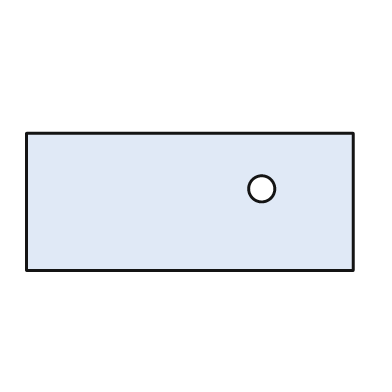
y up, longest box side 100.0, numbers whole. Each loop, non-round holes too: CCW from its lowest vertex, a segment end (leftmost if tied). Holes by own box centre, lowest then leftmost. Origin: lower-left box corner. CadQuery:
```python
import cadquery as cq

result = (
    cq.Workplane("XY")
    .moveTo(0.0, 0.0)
    .lineTo(100.0, 0.0)
    .lineTo(100.0, 42.0)
    .lineTo(0.0, 42.0)
    .close()
    .moveTo(72.0, 25.0)
    .circle(4.0)
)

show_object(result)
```